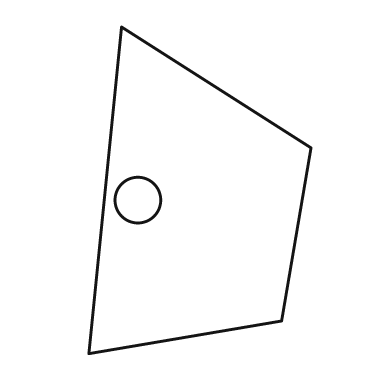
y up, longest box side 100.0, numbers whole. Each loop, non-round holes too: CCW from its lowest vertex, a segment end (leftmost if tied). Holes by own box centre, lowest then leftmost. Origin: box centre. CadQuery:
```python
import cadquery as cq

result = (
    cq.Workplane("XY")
    .moveTo(-34.0, -50.0)
    .lineTo(25.0, -40.0)
    .lineTo(34.0, 13.0)
    .lineTo(-24.0, 50.0)
    .close()
    .moveTo(-19.0, -3.0)
    .circle(7.0)
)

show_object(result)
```